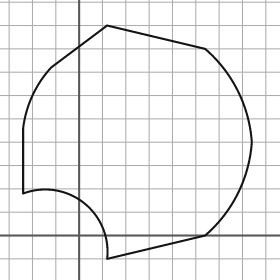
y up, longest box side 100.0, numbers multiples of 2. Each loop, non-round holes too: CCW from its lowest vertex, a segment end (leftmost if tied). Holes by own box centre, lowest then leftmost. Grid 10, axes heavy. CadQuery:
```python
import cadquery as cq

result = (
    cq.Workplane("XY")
    .moveTo(12.0, -10.0)
    .lineTo(54.0, 0.0)
    .threePointArc((68.0, 18.0), (74.0, 40.0))
    .threePointArc((68.0, 62.0), (54.0, 80.0))
    .lineTo(12.0, 90.0)
    .lineTo(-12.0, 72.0)
    .threePointArc((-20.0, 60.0), (-24.0, 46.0))
    .lineTo(-24.0, 18.0)
    .threePointArc((2.0, 14.0), (12.0, -10.0))
    .close()
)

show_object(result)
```